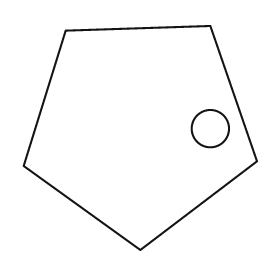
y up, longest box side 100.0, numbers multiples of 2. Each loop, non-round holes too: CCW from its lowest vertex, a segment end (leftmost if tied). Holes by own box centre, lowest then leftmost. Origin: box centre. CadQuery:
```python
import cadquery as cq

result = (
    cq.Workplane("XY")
    .moveTo(0.0, -48.0)
    .lineTo(50.0, -10.0)
    .lineTo(30.0, 48.0)
    .lineTo(-32.0, 46.0)
    .lineTo(-50.0, -12.0)
    .close()
    .moveTo(30.0, 4.0)
    .circle(8.0)
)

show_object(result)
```